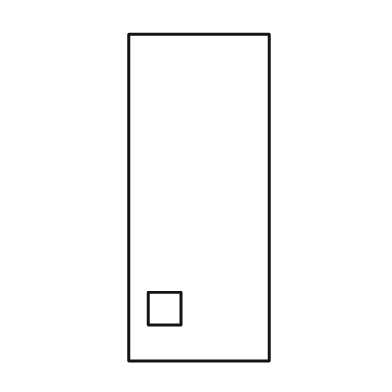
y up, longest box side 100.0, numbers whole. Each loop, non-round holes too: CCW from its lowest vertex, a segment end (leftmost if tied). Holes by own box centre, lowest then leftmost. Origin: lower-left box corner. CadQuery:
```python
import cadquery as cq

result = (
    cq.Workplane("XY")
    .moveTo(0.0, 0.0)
    .lineTo(43.0, 0.0)
    .lineTo(43.0, 100.0)
    .lineTo(0.0, 100.0)
    .close()
    .moveTo(6.0, 11.0)
    .lineTo(16.0, 11.0)
    .lineTo(16.0, 21.0)
    .lineTo(6.0, 21.0)
    .close()
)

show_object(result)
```